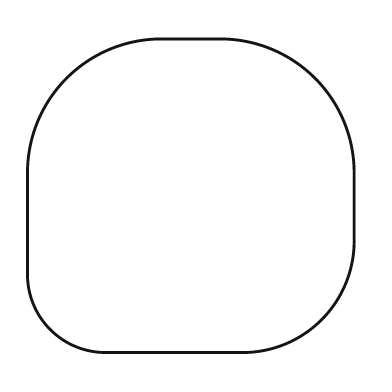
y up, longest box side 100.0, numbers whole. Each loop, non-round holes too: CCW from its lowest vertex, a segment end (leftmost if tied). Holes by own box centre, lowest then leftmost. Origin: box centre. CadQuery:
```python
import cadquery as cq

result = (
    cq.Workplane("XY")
    .moveTo(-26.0, -48.0)
    .lineTo(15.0, -48.0)
    .threePointArc((40.0, -38.0), (50.0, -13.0))
    .lineTo(50.0, 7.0)
    .threePointArc((38.0, 36.0), (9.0, 48.0))
    .lineTo(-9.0, 48.0)
    .threePointArc((-38.0, 36.0), (-50.0, 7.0))
    .lineTo(-50.0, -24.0)
    .threePointArc((-43.0, -41.0), (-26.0, -48.0))
    .close()
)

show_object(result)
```